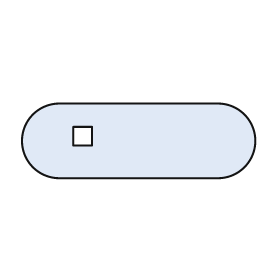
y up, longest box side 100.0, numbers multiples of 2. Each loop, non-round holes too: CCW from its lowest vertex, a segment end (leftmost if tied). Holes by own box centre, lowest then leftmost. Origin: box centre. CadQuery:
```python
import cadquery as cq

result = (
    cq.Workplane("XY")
    .moveTo(-34.0, -16.0)
    .lineTo(34.0, -16.0)
    .threePointArc((50.0, 0.0), (34.0, 16.0))
    .lineTo(-34.0, 16.0)
    .threePointArc((-50.0, 0.0), (-34.0, -16.0))
    .close()
    .moveTo(-28.0, -2.0)
    .lineTo(-20.0, -2.0)
    .lineTo(-20.0, 6.0)
    .lineTo(-28.0, 6.0)
    .close()
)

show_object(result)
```